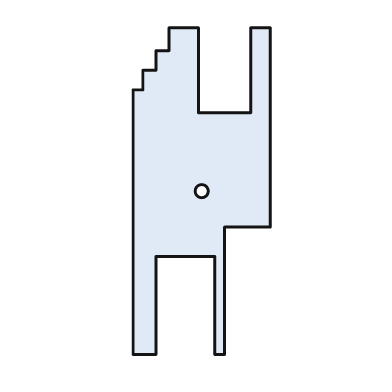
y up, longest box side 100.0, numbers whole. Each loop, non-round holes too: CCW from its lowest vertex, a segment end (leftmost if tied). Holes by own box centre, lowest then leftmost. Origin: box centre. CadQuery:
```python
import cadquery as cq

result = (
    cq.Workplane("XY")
    .moveTo(-21.0, -50.0)
    .lineTo(-14.0, -50.0)
    .lineTo(-14.0, -20.0)
    .lineTo(4.0, -20.0)
    .lineTo(4.0, -50.0)
    .lineTo(7.0, -50.0)
    .lineTo(7.0, -11.0)
    .lineTo(21.0, -11.0)
    .lineTo(21.0, 50.0)
    .lineTo(15.0, 50.0)
    .lineTo(15.0, 24.0)
    .lineTo(-1.0, 24.0)
    .lineTo(-1.0, 50.0)
    .lineTo(-10.0, 50.0)
    .lineTo(-10.0, 43.0)
    .lineTo(-14.0, 43.0)
    .lineTo(-14.0, 37.0)
    .lineTo(-18.0, 37.0)
    .lineTo(-18.0, 31.0)
    .lineTo(-21.0, 31.0)
    .close()
    .moveTo(0.0, 0.0)
    .circle(2.0)
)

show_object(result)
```